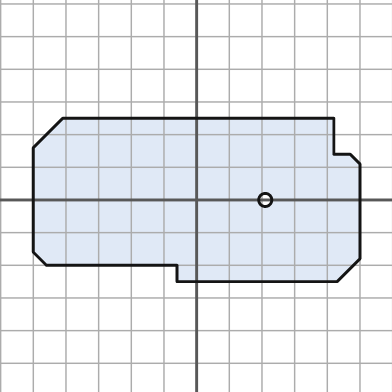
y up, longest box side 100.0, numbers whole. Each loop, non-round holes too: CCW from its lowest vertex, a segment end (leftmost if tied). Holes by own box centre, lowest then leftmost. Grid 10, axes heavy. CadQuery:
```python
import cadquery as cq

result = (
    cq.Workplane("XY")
    .moveTo(-6.0, -25.0)
    .lineTo(43.0, -25.0)
    .lineTo(50.0, -18.0)
    .lineTo(50.0, 11.0)
    .lineTo(47.0, 14.0)
    .lineTo(42.0, 14.0)
    .lineTo(42.0, 25.0)
    .lineTo(-41.0, 25.0)
    .lineTo(-50.0, 16.0)
    .lineTo(-50.0, -16.0)
    .lineTo(-46.0, -20.0)
    .lineTo(-6.0, -20.0)
    .close()
    .moveTo(21.0, 0.0)
    .circle(2.0)
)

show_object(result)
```